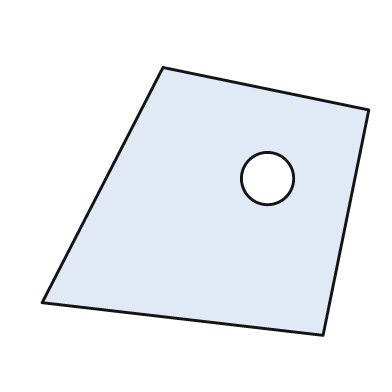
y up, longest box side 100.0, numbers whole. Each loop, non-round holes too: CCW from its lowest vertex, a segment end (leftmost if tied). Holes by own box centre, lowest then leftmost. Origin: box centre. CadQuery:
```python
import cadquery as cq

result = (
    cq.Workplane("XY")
    .moveTo(36.0, -41.0)
    .lineTo(50.0, 28.0)
    .lineTo(-13.0, 41.0)
    .lineTo(-50.0, -31.0)
    .close()
    .moveTo(19.0, 7.0)
    .circle(8.0)
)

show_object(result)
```